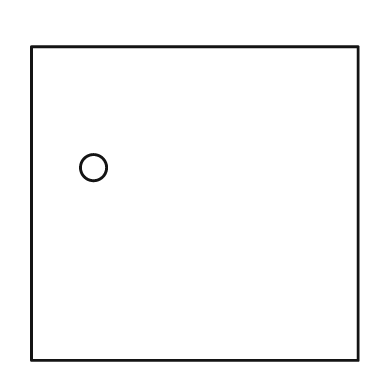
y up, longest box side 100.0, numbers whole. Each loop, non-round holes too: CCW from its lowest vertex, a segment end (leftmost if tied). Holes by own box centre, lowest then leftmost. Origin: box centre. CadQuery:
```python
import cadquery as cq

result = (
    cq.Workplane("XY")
    .moveTo(-50.0, -48.0)
    .lineTo(50.0, -48.0)
    .lineTo(50.0, 48.0)
    .lineTo(-50.0, 48.0)
    .close()
    .moveTo(-31.0, 11.0)
    .circle(4.0)
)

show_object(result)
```